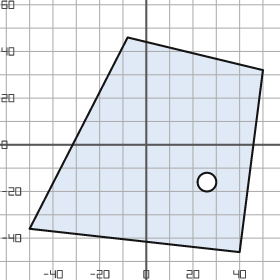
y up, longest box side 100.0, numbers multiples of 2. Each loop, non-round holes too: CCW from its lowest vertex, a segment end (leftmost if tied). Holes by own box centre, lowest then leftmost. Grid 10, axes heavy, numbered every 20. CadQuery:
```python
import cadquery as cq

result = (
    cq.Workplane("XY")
    .moveTo(40.0, -46.0)
    .lineTo(50.0, 32.0)
    .lineTo(-8.0, 46.0)
    .lineTo(-50.0, -36.0)
    .close()
    .moveTo(26.0, -16.0)
    .circle(4.0)
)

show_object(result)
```